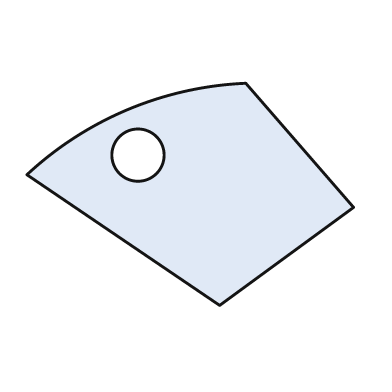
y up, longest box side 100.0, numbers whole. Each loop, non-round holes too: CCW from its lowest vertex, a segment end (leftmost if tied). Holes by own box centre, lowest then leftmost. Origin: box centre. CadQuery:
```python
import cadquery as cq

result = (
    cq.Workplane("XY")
    .moveTo(9.0, -34.0)
    .lineTo(50.0, -4.0)
    .lineTo(17.0, 34.0)
    .threePointArc((-19.0, 26.0), (-50.0, 6.0))
    .close()
    .moveTo(-16.0, 12.0)
    .circle(8.0)
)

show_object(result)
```